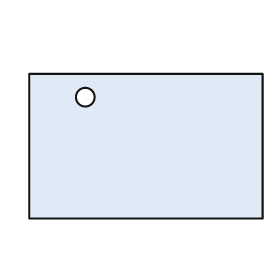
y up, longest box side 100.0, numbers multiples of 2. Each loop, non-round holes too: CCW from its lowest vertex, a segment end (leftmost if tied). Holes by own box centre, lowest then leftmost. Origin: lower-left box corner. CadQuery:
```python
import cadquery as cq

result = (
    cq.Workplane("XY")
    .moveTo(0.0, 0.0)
    .lineTo(100.0, 0.0)
    .lineTo(100.0, 62.0)
    .lineTo(0.0, 62.0)
    .close()
    .moveTo(24.0, 52.0)
    .circle(4.0)
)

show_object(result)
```